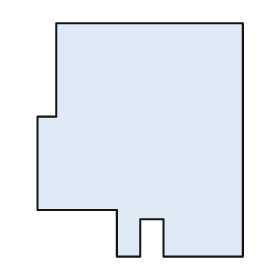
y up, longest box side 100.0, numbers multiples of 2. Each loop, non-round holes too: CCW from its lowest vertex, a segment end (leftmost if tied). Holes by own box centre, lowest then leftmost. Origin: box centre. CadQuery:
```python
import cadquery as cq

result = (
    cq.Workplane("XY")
    .moveTo(-10.0, -50.0)
    .lineTo(0.0, -50.0)
    .lineTo(0.0, -34.0)
    .lineTo(10.0, -34.0)
    .lineTo(10.0, -50.0)
    .lineTo(44.0, -50.0)
    .lineTo(44.0, 50.0)
    .lineTo(-36.0, 50.0)
    .lineTo(-36.0, 10.0)
    .lineTo(-44.0, 10.0)
    .lineTo(-44.0, -30.0)
    .lineTo(-10.0, -30.0)
    .close()
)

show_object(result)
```